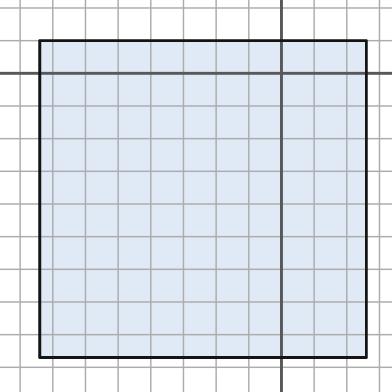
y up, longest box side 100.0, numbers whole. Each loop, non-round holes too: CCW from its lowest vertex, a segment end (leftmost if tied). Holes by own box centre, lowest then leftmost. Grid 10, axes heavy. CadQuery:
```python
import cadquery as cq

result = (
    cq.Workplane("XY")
    .moveTo(-74.0, -87.0)
    .lineTo(26.0, -87.0)
    .lineTo(26.0, 10.0)
    .lineTo(-74.0, 10.0)
    .close()
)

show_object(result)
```